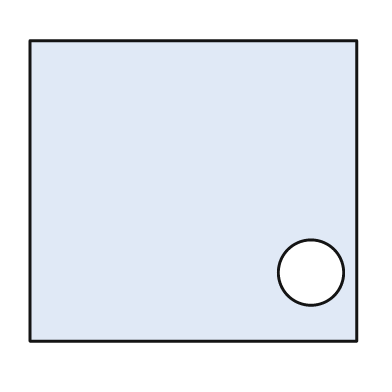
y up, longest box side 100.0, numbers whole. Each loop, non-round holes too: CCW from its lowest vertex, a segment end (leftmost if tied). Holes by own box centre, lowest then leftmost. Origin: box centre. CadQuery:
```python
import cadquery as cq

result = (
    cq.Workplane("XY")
    .moveTo(-50.0, -46.0)
    .lineTo(50.0, -46.0)
    .lineTo(50.0, 46.0)
    .lineTo(-50.0, 46.0)
    .close()
    .moveTo(36.0, -25.0)
    .circle(10.0)
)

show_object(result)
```